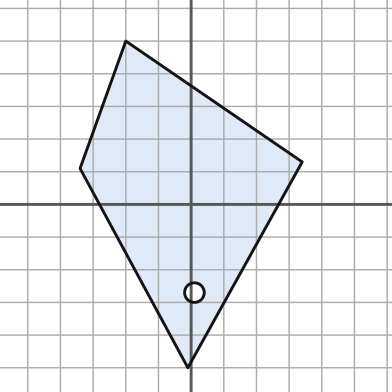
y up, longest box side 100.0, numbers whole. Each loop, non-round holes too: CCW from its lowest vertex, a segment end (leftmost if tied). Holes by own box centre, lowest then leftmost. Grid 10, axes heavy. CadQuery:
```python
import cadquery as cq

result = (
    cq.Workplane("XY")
    .moveTo(-1.0, -50.0)
    .lineTo(34.0, 13.0)
    .lineTo(-20.0, 50.0)
    .lineTo(-34.0, 11.0)
    .close()
    .moveTo(1.0, -27.0)
    .circle(3.0)
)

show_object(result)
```